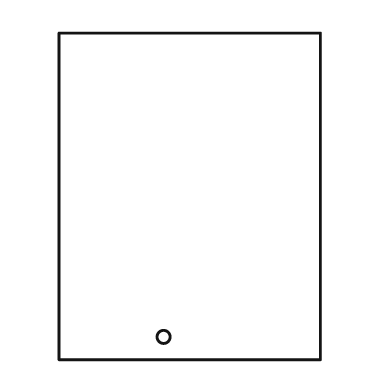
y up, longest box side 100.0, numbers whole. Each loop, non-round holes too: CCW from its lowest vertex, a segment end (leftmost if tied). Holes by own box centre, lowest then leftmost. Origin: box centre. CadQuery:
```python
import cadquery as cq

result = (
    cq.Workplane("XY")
    .moveTo(-40.0, -50.0)
    .lineTo(40.0, -50.0)
    .lineTo(40.0, 50.0)
    .lineTo(-40.0, 50.0)
    .close()
    .moveTo(-8.0, -43.0)
    .circle(2.0)
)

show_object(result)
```